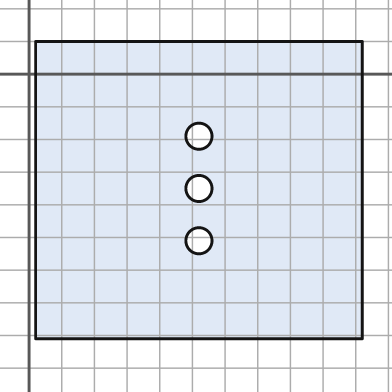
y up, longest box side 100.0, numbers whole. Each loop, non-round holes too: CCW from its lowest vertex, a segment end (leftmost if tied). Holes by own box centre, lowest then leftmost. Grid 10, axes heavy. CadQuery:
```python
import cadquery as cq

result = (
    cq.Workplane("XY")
    .moveTo(2.0, -81.0)
    .lineTo(102.0, -81.0)
    .lineTo(102.0, 10.0)
    .lineTo(2.0, 10.0)
    .close()
    .moveTo(52.0, -51.0)
    .circle(4.0)
    .moveTo(52.0, -35.0)
    .circle(4.0)
    .moveTo(52.0, -19.0)
    .circle(4.0)
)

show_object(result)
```